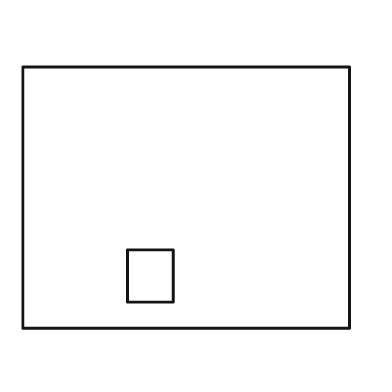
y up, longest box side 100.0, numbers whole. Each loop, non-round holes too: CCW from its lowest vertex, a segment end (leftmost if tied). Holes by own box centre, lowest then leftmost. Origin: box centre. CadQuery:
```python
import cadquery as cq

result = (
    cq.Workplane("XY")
    .moveTo(-50.0, -40.0)
    .lineTo(50.0, -40.0)
    .lineTo(50.0, 40.0)
    .lineTo(-50.0, 40.0)
    .close()
    .moveTo(-18.0, -32.0)
    .lineTo(-4.0, -32.0)
    .lineTo(-4.0, -16.0)
    .lineTo(-18.0, -16.0)
    .close()
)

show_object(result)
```